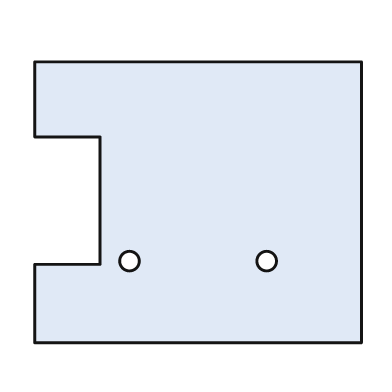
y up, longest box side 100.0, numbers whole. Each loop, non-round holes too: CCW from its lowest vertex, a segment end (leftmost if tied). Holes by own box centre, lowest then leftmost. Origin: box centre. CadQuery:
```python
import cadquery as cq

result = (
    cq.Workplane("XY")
    .moveTo(-50.0, -43.0)
    .lineTo(50.0, -43.0)
    .lineTo(50.0, 43.0)
    .lineTo(-50.0, 43.0)
    .lineTo(-50.0, 20.0)
    .lineTo(-30.0, 20.0)
    .lineTo(-30.0, -19.0)
    .lineTo(-50.0, -19.0)
    .close()
    .moveTo(-21.0, -18.0)
    .circle(3.0)
    .moveTo(21.0, -18.0)
    .circle(3.0)
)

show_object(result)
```